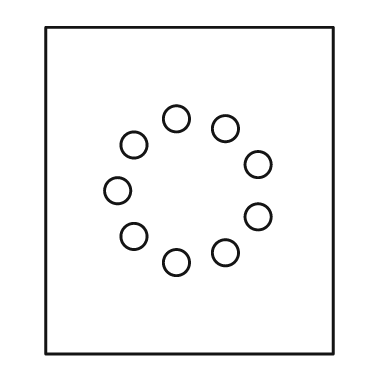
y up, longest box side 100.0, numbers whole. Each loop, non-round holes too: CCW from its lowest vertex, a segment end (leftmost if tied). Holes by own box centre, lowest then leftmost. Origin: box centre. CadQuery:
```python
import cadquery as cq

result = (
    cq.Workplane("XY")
    .moveTo(-44.0, -50.0)
    .lineTo(44.0, -50.0)
    .lineTo(44.0, 50.0)
    .lineTo(-44.0, 50.0)
    .close()
    .moveTo(-4.0, -22.0)
    .circle(4.0)
    .moveTo(11.0, -19.0)
    .circle(4.0)
    .moveTo(-17.0, -14.0)
    .circle(4.0)
    .moveTo(21.0, -8.0)
    .circle(4.0)
    .moveTo(-22.0, 0.0)
    .circle(4.0)
    .moveTo(21.0, 8.0)
    .circle(4.0)
    .moveTo(-17.0, 14.0)
    .circle(4.0)
    .moveTo(11.0, 19.0)
    .circle(4.0)
    .moveTo(-4.0, 22.0)
    .circle(4.0)
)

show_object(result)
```